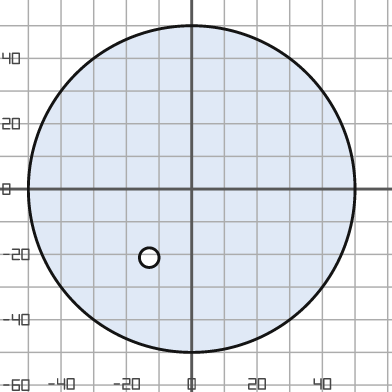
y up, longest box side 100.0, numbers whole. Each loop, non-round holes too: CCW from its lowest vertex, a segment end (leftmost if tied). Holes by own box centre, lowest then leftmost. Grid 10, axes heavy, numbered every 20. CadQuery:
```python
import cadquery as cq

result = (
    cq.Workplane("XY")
    .moveTo(0.0, 0.0)
    .circle(50.0)
    .moveTo(-13.0, -21.0)
    .circle(3.0)
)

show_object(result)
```